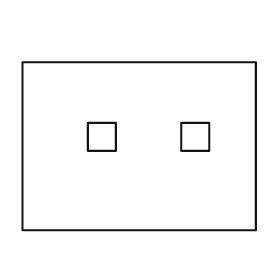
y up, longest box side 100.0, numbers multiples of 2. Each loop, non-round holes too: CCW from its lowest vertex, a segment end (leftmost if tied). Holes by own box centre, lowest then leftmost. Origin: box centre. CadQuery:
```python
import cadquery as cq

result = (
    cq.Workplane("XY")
    .moveTo(-50.0, -36.0)
    .lineTo(50.0, -36.0)
    .lineTo(50.0, 36.0)
    .lineTo(-50.0, 36.0)
    .close()
    .moveTo(-22.0, -2.0)
    .lineTo(-10.0, -2.0)
    .lineTo(-10.0, 10.0)
    .lineTo(-22.0, 10.0)
    .close()
    .moveTo(18.0, -2.0)
    .lineTo(30.0, -2.0)
    .lineTo(30.0, 10.0)
    .lineTo(18.0, 10.0)
    .close()
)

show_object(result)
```